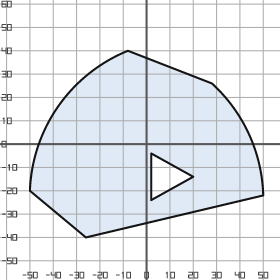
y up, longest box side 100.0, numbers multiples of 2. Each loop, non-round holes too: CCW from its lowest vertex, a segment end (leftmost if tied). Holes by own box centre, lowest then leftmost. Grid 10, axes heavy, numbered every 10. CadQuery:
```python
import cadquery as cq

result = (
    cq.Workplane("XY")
    .moveTo(-26.0, -40.0)
    .lineTo(50.0, -22.0)
    .threePointArc((44.0, 4.0), (28.0, 26.0))
    .lineTo(-8.0, 40.0)
    .threePointArc((-38.0, 16.0), (-50.0, -20.0))
    .close()
    .moveTo(2.0, -24.0)
    .lineTo(20.0, -14.0)
    .lineTo(2.0, -4.0)
    .close()
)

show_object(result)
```